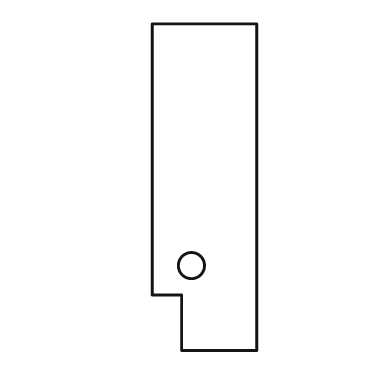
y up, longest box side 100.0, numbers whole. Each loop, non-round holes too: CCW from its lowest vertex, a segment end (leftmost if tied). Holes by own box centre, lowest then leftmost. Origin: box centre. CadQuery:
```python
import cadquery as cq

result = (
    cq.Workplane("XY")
    .moveTo(-7.0, -50.0)
    .lineTo(16.0, -50.0)
    .lineTo(16.0, 50.0)
    .lineTo(-16.0, 50.0)
    .lineTo(-16.0, -33.0)
    .lineTo(-7.0, -33.0)
    .close()
    .moveTo(-4.0, -24.0)
    .circle(4.0)
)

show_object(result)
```